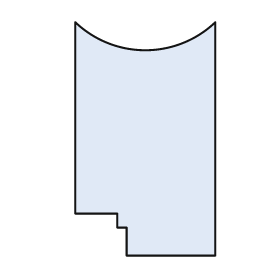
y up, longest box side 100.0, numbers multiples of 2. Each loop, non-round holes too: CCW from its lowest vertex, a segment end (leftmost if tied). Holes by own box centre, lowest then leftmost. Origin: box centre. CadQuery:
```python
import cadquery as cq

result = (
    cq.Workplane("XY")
    .moveTo(-8.0, -50.0)
    .lineTo(30.0, -50.0)
    .lineTo(30.0, 50.0)
    .threePointArc((0.0, 38.0), (-30.0, 50.0))
    .lineTo(-30.0, -32.0)
    .lineTo(-12.0, -32.0)
    .lineTo(-12.0, -38.0)
    .lineTo(-8.0, -38.0)
    .close()
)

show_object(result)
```